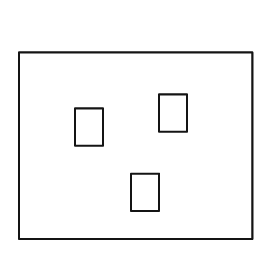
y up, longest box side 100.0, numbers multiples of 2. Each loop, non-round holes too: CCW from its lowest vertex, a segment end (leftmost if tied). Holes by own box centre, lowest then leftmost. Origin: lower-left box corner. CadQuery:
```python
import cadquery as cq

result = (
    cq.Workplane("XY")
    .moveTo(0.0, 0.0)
    .lineTo(100.0, 0.0)
    .lineTo(100.0, 80.0)
    .lineTo(0.0, 80.0)
    .close()
    .moveTo(48.0, 12.0)
    .lineTo(60.0, 12.0)
    .lineTo(60.0, 28.0)
    .lineTo(48.0, 28.0)
    .close()
    .moveTo(24.0, 40.0)
    .lineTo(36.0, 40.0)
    .lineTo(36.0, 56.0)
    .lineTo(24.0, 56.0)
    .close()
    .moveTo(60.0, 46.0)
    .lineTo(72.0, 46.0)
    .lineTo(72.0, 62.0)
    .lineTo(60.0, 62.0)
    .close()
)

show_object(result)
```